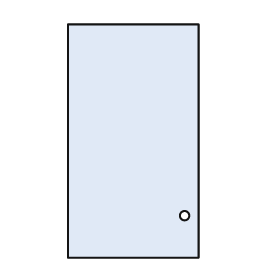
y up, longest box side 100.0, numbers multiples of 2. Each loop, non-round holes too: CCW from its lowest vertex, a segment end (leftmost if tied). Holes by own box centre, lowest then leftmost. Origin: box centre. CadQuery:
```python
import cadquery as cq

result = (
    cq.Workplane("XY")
    .moveTo(-28.0, -50.0)
    .lineTo(28.0, -50.0)
    .lineTo(28.0, 50.0)
    .lineTo(-28.0, 50.0)
    .close()
    .moveTo(22.0, -32.0)
    .circle(2.0)
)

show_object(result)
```